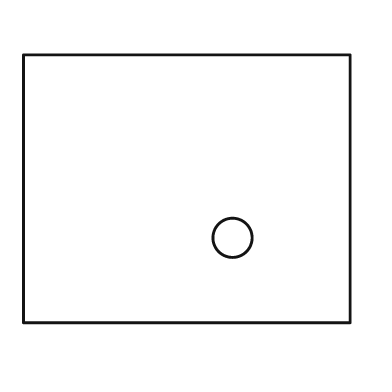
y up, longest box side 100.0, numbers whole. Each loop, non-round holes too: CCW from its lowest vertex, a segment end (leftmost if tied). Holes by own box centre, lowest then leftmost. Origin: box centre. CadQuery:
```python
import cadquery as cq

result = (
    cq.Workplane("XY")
    .moveTo(-50.0, -41.0)
    .lineTo(50.0, -41.0)
    .lineTo(50.0, 41.0)
    .lineTo(-50.0, 41.0)
    .close()
    .moveTo(14.0, -15.0)
    .circle(6.0)
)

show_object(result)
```